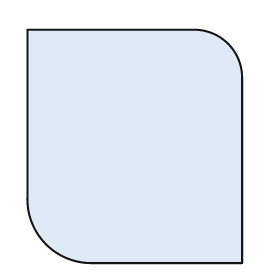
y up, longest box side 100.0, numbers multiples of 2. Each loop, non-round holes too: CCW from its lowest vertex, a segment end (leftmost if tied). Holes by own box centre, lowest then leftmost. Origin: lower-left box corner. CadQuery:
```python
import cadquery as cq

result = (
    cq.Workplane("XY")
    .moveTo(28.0, 0.0)
    .lineTo(92.0, 0.0)
    .lineTo(92.0, 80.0)
    .threePointArc((86.0, 94.0), (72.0, 100.0))
    .lineTo(0.0, 100.0)
    .lineTo(0.0, 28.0)
    .threePointArc((8.0, 8.0), (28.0, 0.0))
    .close()
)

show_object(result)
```